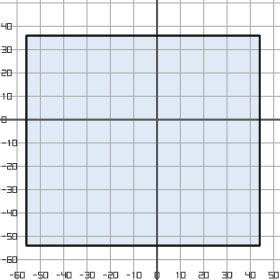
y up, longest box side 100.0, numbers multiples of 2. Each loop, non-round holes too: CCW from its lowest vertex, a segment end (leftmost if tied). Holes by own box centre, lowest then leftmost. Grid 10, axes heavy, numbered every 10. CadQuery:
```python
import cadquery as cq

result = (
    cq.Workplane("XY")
    .moveTo(-56.0, -54.0)
    .lineTo(44.0, -54.0)
    .lineTo(44.0, 36.0)
    .lineTo(-56.0, 36.0)
    .close()
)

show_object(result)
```